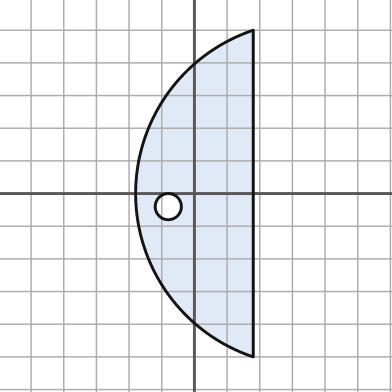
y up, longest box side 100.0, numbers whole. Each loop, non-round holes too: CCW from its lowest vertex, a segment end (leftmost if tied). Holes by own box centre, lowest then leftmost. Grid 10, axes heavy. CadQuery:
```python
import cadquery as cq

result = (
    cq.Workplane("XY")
    .moveTo(18.0, -50.0)
    .lineTo(18.0, 50.0)
    .threePointArc((-18.0, 0.0), (18.0, -50.0))
    .close()
    .moveTo(-8.0, -4.0)
    .circle(4.0)
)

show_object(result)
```